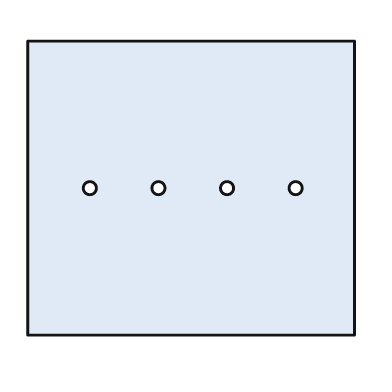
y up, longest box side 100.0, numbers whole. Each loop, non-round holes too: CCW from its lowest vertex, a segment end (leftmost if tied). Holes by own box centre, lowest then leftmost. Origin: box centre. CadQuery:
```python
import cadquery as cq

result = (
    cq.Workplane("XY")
    .moveTo(-50.0, -45.0)
    .lineTo(50.0, -45.0)
    .lineTo(50.0, 45.0)
    .lineTo(-50.0, 45.0)
    .close()
    .moveTo(-31.0, 0.0)
    .circle(2.0)
    .moveTo(-10.0, 0.0)
    .circle(2.0)
    .moveTo(11.0, 0.0)
    .circle(2.0)
    .moveTo(32.0, 0.0)
    .circle(2.0)
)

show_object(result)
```